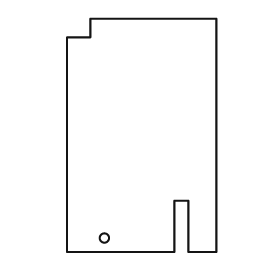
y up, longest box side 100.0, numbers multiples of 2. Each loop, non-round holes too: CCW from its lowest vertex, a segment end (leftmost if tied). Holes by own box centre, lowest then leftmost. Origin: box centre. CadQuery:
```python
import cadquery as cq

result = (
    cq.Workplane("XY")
    .moveTo(-32.0, -50.0)
    .lineTo(14.0, -50.0)
    .lineTo(14.0, -28.0)
    .lineTo(20.0, -28.0)
    .lineTo(20.0, -50.0)
    .lineTo(32.0, -50.0)
    .lineTo(32.0, 50.0)
    .lineTo(-22.0, 50.0)
    .lineTo(-22.0, 42.0)
    .lineTo(-32.0, 42.0)
    .close()
    .moveTo(-16.0, -44.0)
    .circle(2.0)
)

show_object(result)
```